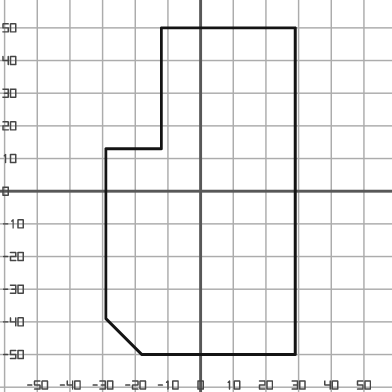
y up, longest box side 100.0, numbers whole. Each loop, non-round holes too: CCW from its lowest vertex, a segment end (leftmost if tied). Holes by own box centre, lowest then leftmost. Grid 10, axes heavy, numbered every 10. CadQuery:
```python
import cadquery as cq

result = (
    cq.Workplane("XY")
    .moveTo(-18.0, -50.0)
    .lineTo(29.0, -50.0)
    .lineTo(29.0, 50.0)
    .lineTo(-12.0, 50.0)
    .lineTo(-12.0, 13.0)
    .lineTo(-29.0, 13.0)
    .lineTo(-29.0, -39.0)
    .close()
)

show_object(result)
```